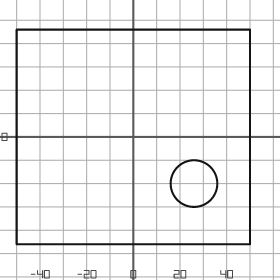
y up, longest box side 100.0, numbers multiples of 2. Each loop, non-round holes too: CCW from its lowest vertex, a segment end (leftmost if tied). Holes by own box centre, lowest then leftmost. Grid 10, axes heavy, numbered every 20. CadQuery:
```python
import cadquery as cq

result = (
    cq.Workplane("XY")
    .moveTo(-50.0, -46.0)
    .lineTo(50.0, -46.0)
    .lineTo(50.0, 46.0)
    .lineTo(-50.0, 46.0)
    .close()
    .moveTo(26.0, -20.0)
    .circle(10.0)
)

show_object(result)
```